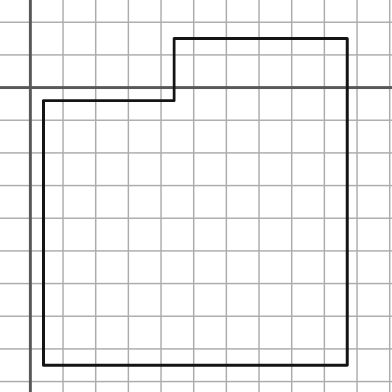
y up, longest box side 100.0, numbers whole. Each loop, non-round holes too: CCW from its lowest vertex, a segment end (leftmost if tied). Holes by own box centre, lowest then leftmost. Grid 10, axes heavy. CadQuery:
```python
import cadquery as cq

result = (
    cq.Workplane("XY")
    .moveTo(4.0, -85.0)
    .lineTo(97.0, -85.0)
    .lineTo(97.0, 15.0)
    .lineTo(44.0, 15.0)
    .lineTo(44.0, -4.0)
    .lineTo(4.0, -4.0)
    .close()
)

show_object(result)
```